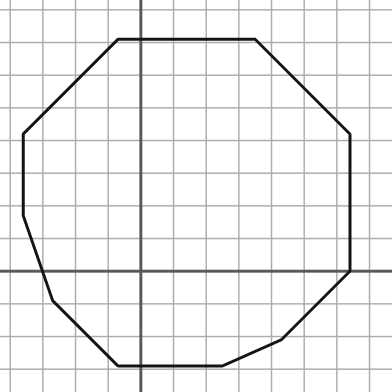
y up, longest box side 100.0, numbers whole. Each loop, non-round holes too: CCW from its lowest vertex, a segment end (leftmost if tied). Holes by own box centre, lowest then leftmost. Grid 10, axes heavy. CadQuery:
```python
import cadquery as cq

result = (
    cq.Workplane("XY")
    .moveTo(-7.0, -29.0)
    .lineTo(25.0, -29.0)
    .lineTo(43.0, -21.0)
    .lineTo(64.0, 0.0)
    .lineTo(64.0, 42.0)
    .lineTo(35.0, 71.0)
    .lineTo(-7.0, 71.0)
    .lineTo(-36.0, 42.0)
    .lineTo(-36.0, 17.0)
    .lineTo(-27.0, -9.0)
    .close()
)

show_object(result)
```